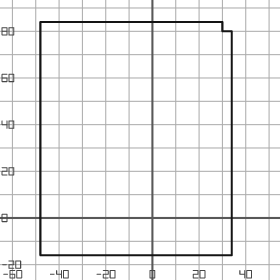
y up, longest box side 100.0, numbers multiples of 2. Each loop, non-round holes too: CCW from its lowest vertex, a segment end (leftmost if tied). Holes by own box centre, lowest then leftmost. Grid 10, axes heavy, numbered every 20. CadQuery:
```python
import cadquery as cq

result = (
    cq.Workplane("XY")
    .moveTo(-48.0, -16.0)
    .lineTo(34.0, -16.0)
    .lineTo(34.0, 80.0)
    .lineTo(30.0, 80.0)
    .lineTo(30.0, 84.0)
    .lineTo(-48.0, 84.0)
    .close()
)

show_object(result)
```